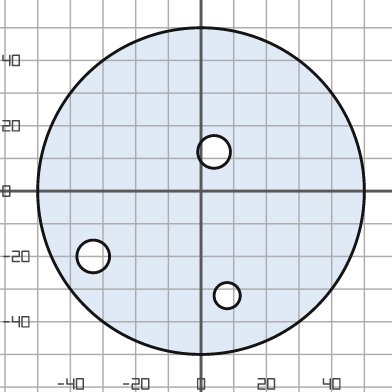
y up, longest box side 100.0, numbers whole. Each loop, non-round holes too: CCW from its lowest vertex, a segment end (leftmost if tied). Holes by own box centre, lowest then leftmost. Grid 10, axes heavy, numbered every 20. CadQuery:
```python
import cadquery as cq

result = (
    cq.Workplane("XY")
    .moveTo(0.0, 0.0)
    .circle(50.0)
    .moveTo(8.0, -32.0)
    .circle(4.0)
    .moveTo(-33.0, -20.0)
    .circle(5.0)
    .moveTo(4.0, 12.0)
    .circle(5.0)
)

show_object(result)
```